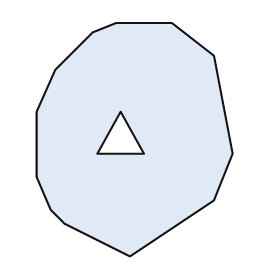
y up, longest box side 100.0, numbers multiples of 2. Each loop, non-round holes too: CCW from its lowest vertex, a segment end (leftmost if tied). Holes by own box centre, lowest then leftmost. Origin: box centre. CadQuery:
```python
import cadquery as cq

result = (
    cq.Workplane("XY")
    .moveTo(-2.0, -50.0)
    .lineTo(34.0, -26.0)
    .lineTo(42.0, -6.0)
    .lineTo(34.0, 36.0)
    .lineTo(16.0, 50.0)
    .lineTo(-8.0, 50.0)
    .lineTo(-18.0, 46.0)
    .lineTo(-34.0, 30.0)
    .lineTo(-42.0, 12.0)
    .lineTo(-42.0, -16.0)
    .lineTo(-36.0, -30.0)
    .lineTo(-30.0, -36.0)
    .close()
    .moveTo(-16.0, -6.0)
    .lineTo(4.0, -6.0)
    .lineTo(-6.0, 12.0)
    .close()
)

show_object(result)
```